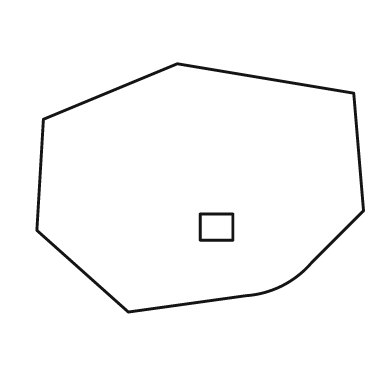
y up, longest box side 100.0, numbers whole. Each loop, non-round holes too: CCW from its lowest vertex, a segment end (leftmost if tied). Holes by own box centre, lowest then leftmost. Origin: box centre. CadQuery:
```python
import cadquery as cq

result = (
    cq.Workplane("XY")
    .moveTo(-22.0, -38.0)
    .lineTo(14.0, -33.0)
    .threePointArc((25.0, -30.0), (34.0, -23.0))
    .lineTo(50.0, -7.0)
    .lineTo(47.0, 29.0)
    .lineTo(-7.0, 38.0)
    .lineTo(-48.0, 21.0)
    .lineTo(-50.0, -13.0)
    .close()
    .moveTo(0.0, -16.0)
    .lineTo(10.0, -16.0)
    .lineTo(10.0, -8.0)
    .lineTo(0.0, -8.0)
    .close()
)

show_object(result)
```